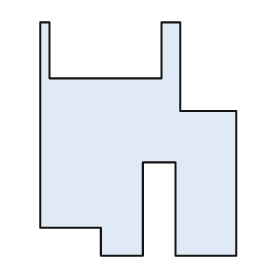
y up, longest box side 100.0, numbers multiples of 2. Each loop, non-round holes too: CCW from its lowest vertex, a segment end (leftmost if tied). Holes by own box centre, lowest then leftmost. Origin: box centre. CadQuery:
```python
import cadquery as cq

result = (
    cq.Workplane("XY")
    .moveTo(-16.0, -50.0)
    .lineTo(2.0, -50.0)
    .lineTo(2.0, -10.0)
    .lineTo(16.0, -10.0)
    .lineTo(16.0, -50.0)
    .lineTo(42.0, -50.0)
    .lineTo(42.0, 12.0)
    .lineTo(18.0, 12.0)
    .lineTo(18.0, 50.0)
    .lineTo(10.0, 50.0)
    .lineTo(10.0, 26.0)
    .lineTo(-38.0, 26.0)
    .lineTo(-38.0, 50.0)
    .lineTo(-42.0, 50.0)
    .lineTo(-42.0, -38.0)
    .lineTo(-16.0, -38.0)
    .close()
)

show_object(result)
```